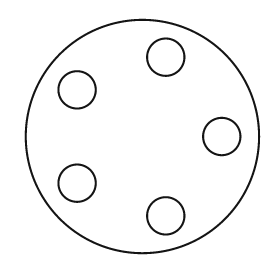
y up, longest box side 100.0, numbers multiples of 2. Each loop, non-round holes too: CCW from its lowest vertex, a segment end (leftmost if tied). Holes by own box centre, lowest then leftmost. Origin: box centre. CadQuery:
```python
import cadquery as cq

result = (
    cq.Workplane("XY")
    .moveTo(0.0, 0.0)
    .circle(50.0)
    .moveTo(10.0, -34.0)
    .circle(8.0)
    .moveTo(-28.0, -20.0)
    .circle(8.0)
    .moveTo(34.0, 0.0)
    .circle(8.0)
    .moveTo(-28.0, 20.0)
    .circle(8.0)
    .moveTo(10.0, 34.0)
    .circle(8.0)
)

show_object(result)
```